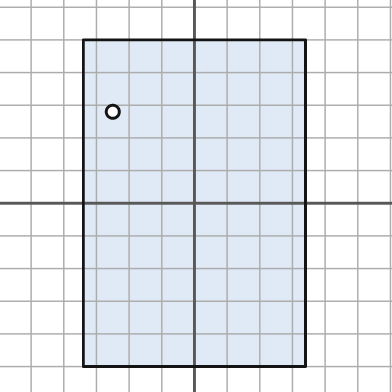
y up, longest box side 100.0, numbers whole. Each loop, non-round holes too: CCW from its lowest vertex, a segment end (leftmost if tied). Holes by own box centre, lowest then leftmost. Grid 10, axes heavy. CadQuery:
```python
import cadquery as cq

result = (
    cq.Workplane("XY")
    .moveTo(-34.0, -50.0)
    .lineTo(34.0, -50.0)
    .lineTo(34.0, 50.0)
    .lineTo(-34.0, 50.0)
    .close()
    .moveTo(-25.0, 28.0)
    .circle(2.0)
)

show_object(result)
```